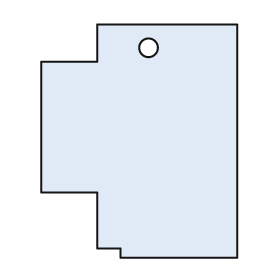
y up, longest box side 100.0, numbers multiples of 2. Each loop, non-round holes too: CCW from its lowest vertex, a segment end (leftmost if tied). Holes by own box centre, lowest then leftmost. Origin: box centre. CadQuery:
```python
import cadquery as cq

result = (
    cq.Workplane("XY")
    .moveTo(-8.0, -50.0)
    .lineTo(42.0, -50.0)
    .lineTo(42.0, 50.0)
    .lineTo(-18.0, 50.0)
    .lineTo(-18.0, 34.0)
    .lineTo(-42.0, 34.0)
    .lineTo(-42.0, -22.0)
    .lineTo(-18.0, -22.0)
    .lineTo(-18.0, -46.0)
    .lineTo(-8.0, -46.0)
    .close()
    .moveTo(4.0, 40.0)
    .circle(4.0)
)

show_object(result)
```